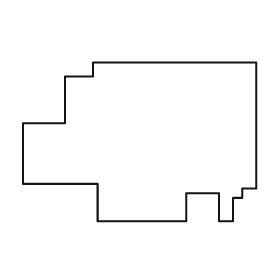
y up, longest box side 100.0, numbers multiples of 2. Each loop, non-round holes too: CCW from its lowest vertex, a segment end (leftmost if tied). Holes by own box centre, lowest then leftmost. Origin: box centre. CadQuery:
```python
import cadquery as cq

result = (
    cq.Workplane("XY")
    .moveTo(-18.0, -34.0)
    .lineTo(20.0, -34.0)
    .lineTo(20.0, -22.0)
    .lineTo(34.0, -22.0)
    .lineTo(34.0, -34.0)
    .lineTo(40.0, -34.0)
    .lineTo(40.0, -24.0)
    .lineTo(44.0, -24.0)
    .lineTo(44.0, -20.0)
    .lineTo(50.0, -20.0)
    .lineTo(50.0, 34.0)
    .lineTo(-20.0, 34.0)
    .lineTo(-20.0, 28.0)
    .lineTo(-32.0, 28.0)
    .lineTo(-32.0, 8.0)
    .lineTo(-50.0, 8.0)
    .lineTo(-50.0, -18.0)
    .lineTo(-18.0, -18.0)
    .close()
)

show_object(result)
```